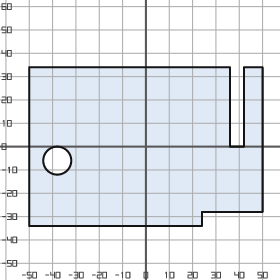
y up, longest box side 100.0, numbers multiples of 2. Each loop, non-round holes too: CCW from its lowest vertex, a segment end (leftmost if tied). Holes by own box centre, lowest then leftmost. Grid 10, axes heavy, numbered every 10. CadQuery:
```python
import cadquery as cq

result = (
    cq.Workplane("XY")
    .moveTo(-50.0, -34.0)
    .lineTo(24.0, -34.0)
    .lineTo(24.0, -28.0)
    .lineTo(50.0, -28.0)
    .lineTo(50.0, 34.0)
    .lineTo(42.0, 34.0)
    .lineTo(42.0, 0.0)
    .lineTo(36.0, 0.0)
    .lineTo(36.0, 34.0)
    .lineTo(-50.0, 34.0)
    .close()
    .moveTo(-38.0, -6.0)
    .circle(6.0)
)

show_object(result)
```